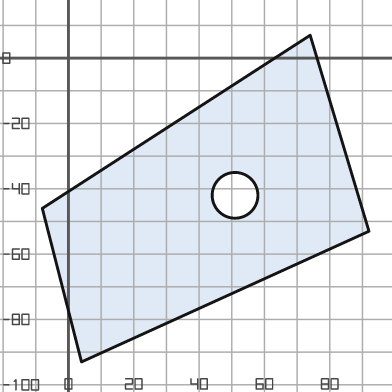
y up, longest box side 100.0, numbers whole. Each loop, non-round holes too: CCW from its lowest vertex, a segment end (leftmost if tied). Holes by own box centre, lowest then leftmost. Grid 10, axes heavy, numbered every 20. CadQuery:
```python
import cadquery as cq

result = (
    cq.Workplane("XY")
    .moveTo(4.0, -93.0)
    .lineTo(92.0, -53.0)
    .lineTo(74.0, 7.0)
    .lineTo(-8.0, -46.0)
    .close()
    .moveTo(51.0, -42.0)
    .circle(7.0)
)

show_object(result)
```